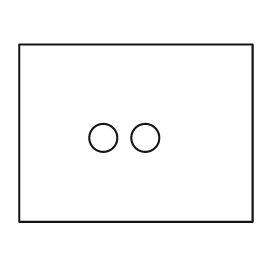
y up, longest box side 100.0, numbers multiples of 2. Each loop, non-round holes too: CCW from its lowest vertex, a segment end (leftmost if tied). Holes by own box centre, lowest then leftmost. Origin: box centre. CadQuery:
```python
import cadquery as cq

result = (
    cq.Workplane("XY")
    .moveTo(-50.0, -38.0)
    .lineTo(50.0, -38.0)
    .lineTo(50.0, 38.0)
    .lineTo(-50.0, 38.0)
    .close()
    .moveTo(-14.0, -2.0)
    .circle(6.0)
    .moveTo(4.0, -2.0)
    .circle(6.0)
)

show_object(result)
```